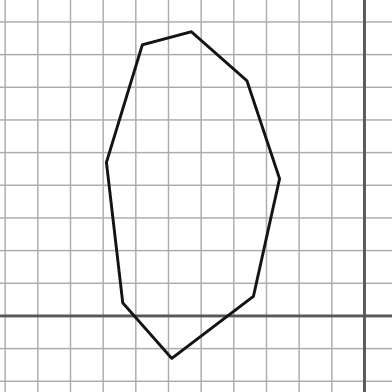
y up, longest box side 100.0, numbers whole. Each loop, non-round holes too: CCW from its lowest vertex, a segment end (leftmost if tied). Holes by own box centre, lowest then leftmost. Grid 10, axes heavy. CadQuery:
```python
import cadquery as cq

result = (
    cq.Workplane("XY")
    .moveTo(-59.0, -13.0)
    .lineTo(-34.0, 6.0)
    .lineTo(-26.0, 42.0)
    .lineTo(-36.0, 72.0)
    .lineTo(-53.0, 87.0)
    .lineTo(-68.0, 83.0)
    .lineTo(-79.0, 47.0)
    .lineTo(-74.0, 4.0)
    .close()
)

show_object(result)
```